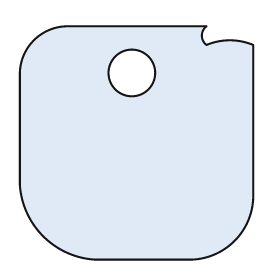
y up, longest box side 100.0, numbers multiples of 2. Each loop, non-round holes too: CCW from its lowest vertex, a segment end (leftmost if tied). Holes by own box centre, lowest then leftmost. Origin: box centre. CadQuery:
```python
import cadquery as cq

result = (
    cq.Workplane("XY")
    .moveTo(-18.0, -50.0)
    .lineTo(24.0, -50.0)
    .threePointArc((42.0, -42.0), (50.0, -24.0))
    .lineTo(50.0, 42.0)
    .threePointArc((40.0, 44.0), (30.0, 42.0))
    .threePointArc((28.0, 46.0), (30.0, 50.0))
    .lineTo(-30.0, 50.0)
    .threePointArc((-44.0, 44.0), (-50.0, 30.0))
    .lineTo(-50.0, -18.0)
    .threePointArc((-40.0, -40.0), (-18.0, -50.0))
    .close()
    .moveTo(-2.0, 30.0)
    .circle(10.0)
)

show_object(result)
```